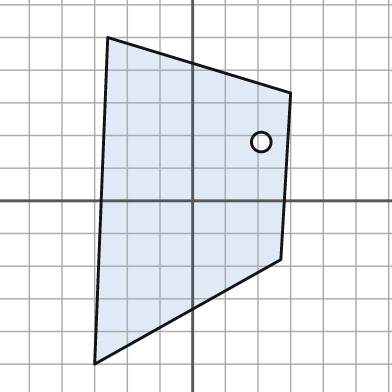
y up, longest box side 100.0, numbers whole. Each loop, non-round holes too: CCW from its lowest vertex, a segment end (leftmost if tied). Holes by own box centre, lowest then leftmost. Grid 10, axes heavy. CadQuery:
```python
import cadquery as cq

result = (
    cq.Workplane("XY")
    .moveTo(-30.0, -50.0)
    .lineTo(27.0, -18.0)
    .lineTo(30.0, 33.0)
    .lineTo(-26.0, 50.0)
    .close()
    .moveTo(21.0, 18.0)
    .circle(3.0)
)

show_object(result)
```